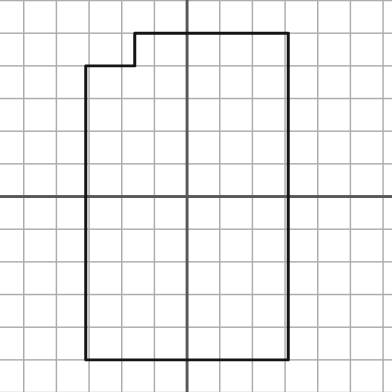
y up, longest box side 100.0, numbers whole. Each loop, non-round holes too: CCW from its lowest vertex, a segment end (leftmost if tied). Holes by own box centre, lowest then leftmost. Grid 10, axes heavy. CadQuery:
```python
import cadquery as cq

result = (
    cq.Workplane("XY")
    .moveTo(-31.0, -50.0)
    .lineTo(31.0, -50.0)
    .lineTo(31.0, 50.0)
    .lineTo(-16.0, 50.0)
    .lineTo(-16.0, 40.0)
    .lineTo(-31.0, 40.0)
    .close()
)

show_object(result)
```